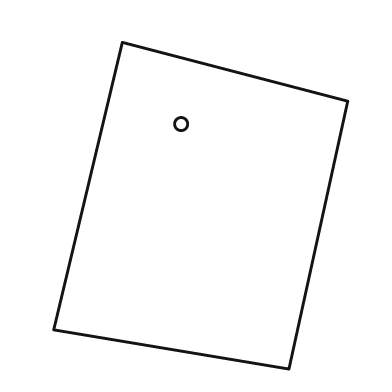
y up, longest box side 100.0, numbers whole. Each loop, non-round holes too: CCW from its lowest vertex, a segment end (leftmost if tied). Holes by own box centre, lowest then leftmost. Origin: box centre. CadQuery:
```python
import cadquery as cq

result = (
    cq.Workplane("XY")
    .moveTo(27.0, -50.0)
    .lineTo(45.0, 32.0)
    .lineTo(-24.0, 50.0)
    .lineTo(-45.0, -38.0)
    .close()
    .moveTo(-6.0, 25.0)
    .circle(2.0)
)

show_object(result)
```